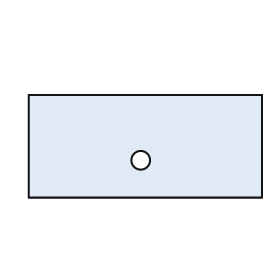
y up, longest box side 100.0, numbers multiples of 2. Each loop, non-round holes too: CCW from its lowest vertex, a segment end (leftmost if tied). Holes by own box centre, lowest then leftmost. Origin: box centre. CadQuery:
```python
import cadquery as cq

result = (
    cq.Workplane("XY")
    .moveTo(-50.0, -22.0)
    .lineTo(50.0, -22.0)
    .lineTo(50.0, 22.0)
    .lineTo(-50.0, 22.0)
    .close()
    .moveTo(-2.0, -6.0)
    .circle(4.0)
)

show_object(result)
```